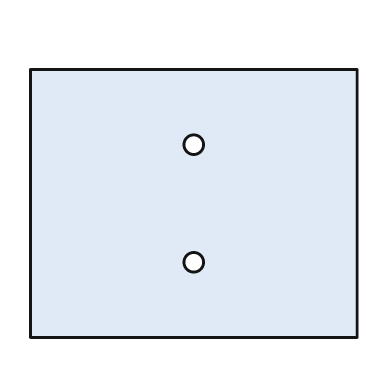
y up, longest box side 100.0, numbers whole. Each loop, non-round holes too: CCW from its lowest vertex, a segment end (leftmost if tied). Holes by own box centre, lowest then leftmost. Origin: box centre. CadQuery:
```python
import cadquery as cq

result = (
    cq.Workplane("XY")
    .moveTo(-50.0, -41.0)
    .lineTo(50.0, -41.0)
    .lineTo(50.0, 41.0)
    .lineTo(-50.0, 41.0)
    .close()
    .moveTo(0.0, -18.0)
    .circle(3.0)
    .moveTo(0.0, 18.0)
    .circle(3.0)
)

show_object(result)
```